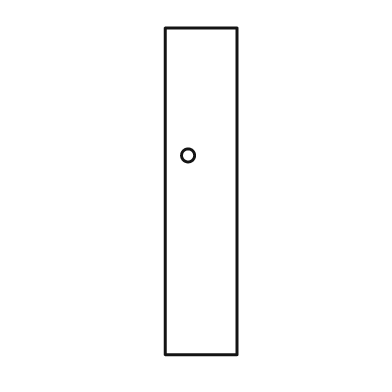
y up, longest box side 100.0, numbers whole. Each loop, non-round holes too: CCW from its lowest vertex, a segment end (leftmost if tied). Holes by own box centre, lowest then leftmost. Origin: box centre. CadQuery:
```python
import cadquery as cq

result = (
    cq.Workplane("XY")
    .moveTo(-11.0, -50.0)
    .lineTo(11.0, -50.0)
    .lineTo(11.0, 50.0)
    .lineTo(-11.0, 50.0)
    .close()
    .moveTo(-4.0, 11.0)
    .circle(2.0)
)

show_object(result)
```